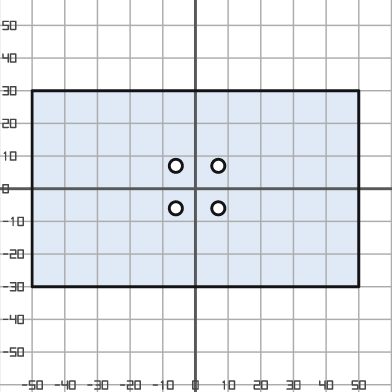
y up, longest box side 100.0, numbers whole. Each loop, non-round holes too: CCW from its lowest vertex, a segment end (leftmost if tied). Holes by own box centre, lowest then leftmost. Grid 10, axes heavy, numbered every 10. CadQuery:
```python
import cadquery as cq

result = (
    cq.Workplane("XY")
    .moveTo(-50.0, -30.0)
    .lineTo(50.0, -30.0)
    .lineTo(50.0, 30.0)
    .lineTo(-50.0, 30.0)
    .close()
    .moveTo(-6.0, -6.0)
    .circle(2.0)
    .moveTo(7.0, -6.0)
    .circle(2.0)
    .moveTo(-6.0, 7.0)
    .circle(2.0)
    .moveTo(7.0, 7.0)
    .circle(2.0)
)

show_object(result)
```